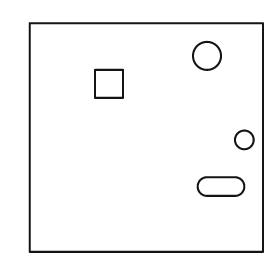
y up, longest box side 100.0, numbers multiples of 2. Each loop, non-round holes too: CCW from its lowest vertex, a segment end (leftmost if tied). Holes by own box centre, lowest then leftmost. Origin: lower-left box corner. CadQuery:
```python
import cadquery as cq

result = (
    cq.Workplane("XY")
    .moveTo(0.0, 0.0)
    .lineTo(100.0, 0.0)
    .lineTo(100.0, 98.0)
    .lineTo(0.0, 98.0)
    .close()
    .moveTo(76.0, 24.0)
    .lineTo(88.0, 24.0)
    .threePointArc((92.0, 28.0), (88.0, 32.0))
    .lineTo(76.0, 32.0)
    .threePointArc((72.0, 28.0), (76.0, 24.0))
    .close()
    .moveTo(92.0, 48.0)
    .circle(4.0)
    .moveTo(28.0, 66.0)
    .lineTo(40.0, 66.0)
    .lineTo(40.0, 78.0)
    .lineTo(28.0, 78.0)
    .close()
    .moveTo(76.0, 84.0)
    .circle(6.0)
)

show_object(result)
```